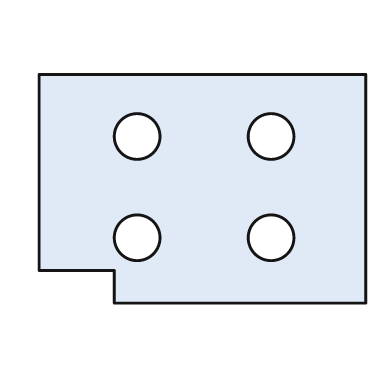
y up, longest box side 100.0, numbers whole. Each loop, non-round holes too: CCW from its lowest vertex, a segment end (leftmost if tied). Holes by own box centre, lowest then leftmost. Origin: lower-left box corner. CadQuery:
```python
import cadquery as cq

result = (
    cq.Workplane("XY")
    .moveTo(23.0, 0.0)
    .lineTo(100.0, 0.0)
    .lineTo(100.0, 70.0)
    .lineTo(0.0, 70.0)
    .lineTo(0.0, 10.0)
    .lineTo(23.0, 10.0)
    .close()
    .moveTo(30.0, 20.0)
    .circle(7.0)
    .moveTo(71.0, 20.0)
    .circle(7.0)
    .moveTo(30.0, 51.0)
    .circle(7.0)
    .moveTo(71.0, 51.0)
    .circle(7.0)
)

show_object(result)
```